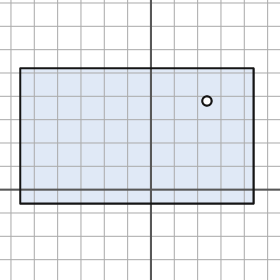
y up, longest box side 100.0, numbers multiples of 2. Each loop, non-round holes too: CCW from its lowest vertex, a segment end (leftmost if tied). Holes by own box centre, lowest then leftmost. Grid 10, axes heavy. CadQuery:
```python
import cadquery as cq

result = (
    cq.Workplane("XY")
    .moveTo(-56.0, -6.0)
    .lineTo(44.0, -6.0)
    .lineTo(44.0, 52.0)
    .lineTo(-56.0, 52.0)
    .close()
    .moveTo(24.0, 38.0)
    .circle(2.0)
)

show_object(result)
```